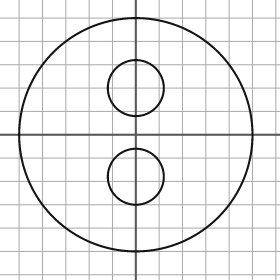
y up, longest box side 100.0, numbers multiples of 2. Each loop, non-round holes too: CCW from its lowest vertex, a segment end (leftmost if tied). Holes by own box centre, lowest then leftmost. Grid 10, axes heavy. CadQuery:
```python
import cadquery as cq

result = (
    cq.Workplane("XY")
    .moveTo(0.0, 0.0)
    .circle(50.0)
    .moveTo(0.0, -18.0)
    .circle(12.0)
    .moveTo(0.0, 20.0)
    .circle(12.0)
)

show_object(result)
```